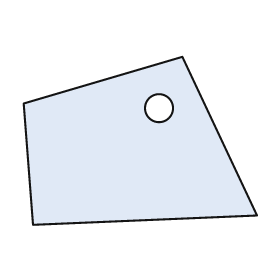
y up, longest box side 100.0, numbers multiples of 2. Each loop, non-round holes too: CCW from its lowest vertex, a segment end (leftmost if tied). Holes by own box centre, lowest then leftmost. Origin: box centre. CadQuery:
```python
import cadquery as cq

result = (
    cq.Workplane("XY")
    .moveTo(-46.0, -36.0)
    .lineTo(50.0, -32.0)
    .lineTo(18.0, 36.0)
    .lineTo(-50.0, 16.0)
    .close()
    .moveTo(8.0, 14.0)
    .circle(6.0)
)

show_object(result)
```